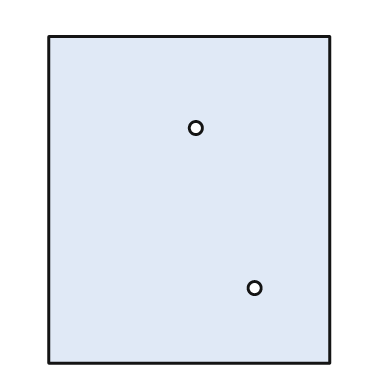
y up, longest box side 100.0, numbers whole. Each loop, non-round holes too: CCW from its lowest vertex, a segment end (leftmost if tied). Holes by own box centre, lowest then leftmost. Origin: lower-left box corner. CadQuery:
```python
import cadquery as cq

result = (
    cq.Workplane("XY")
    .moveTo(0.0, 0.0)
    .lineTo(86.0, 0.0)
    .lineTo(86.0, 100.0)
    .lineTo(0.0, 100.0)
    .close()
    .moveTo(63.0, 23.0)
    .circle(2.0)
    .moveTo(45.0, 72.0)
    .circle(2.0)
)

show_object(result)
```